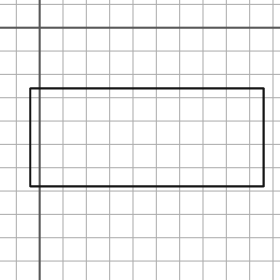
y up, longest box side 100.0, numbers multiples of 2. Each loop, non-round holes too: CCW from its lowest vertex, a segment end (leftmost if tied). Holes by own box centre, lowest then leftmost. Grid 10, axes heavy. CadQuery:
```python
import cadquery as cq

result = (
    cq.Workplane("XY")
    .moveTo(-4.0, -68.0)
    .lineTo(96.0, -68.0)
    .lineTo(96.0, -26.0)
    .lineTo(-4.0, -26.0)
    .close()
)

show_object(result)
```